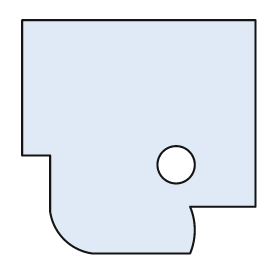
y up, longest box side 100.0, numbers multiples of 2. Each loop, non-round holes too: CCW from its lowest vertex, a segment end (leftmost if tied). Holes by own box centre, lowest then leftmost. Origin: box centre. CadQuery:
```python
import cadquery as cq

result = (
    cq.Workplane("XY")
    .moveTo(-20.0, -50.0)
    .lineTo(22.0, -50.0)
    .threePointArc((24.0, -40.0), (22.0, -30.0))
    .lineTo(50.0, -30.0)
    .lineTo(50.0, 50.0)
    .lineTo(-50.0, 50.0)
    .lineTo(-50.0, -8.0)
    .lineTo(-38.0, -8.0)
    .lineTo(-38.0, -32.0)
    .threePointArc((-32.0, -44.0), (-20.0, -50.0))
    .close()
    .moveTo(16.0, -12.0)
    .circle(8.0)
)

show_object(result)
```